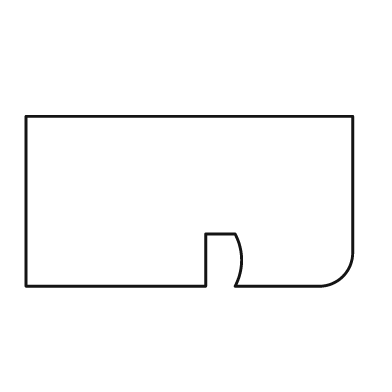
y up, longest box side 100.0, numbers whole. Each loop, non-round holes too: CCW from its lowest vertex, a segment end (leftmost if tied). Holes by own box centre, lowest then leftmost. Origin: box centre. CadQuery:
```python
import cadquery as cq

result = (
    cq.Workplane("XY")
    .moveTo(-50.0, -26.0)
    .lineTo(5.0, -26.0)
    .lineTo(5.0, -10.0)
    .lineTo(14.0, -10.0)
    .threePointArc((16.0, -18.0), (14.0, -26.0))
    .lineTo(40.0, -26.0)
    .threePointArc((47.0, -23.0), (50.0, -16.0))
    .lineTo(50.0, 26.0)
    .lineTo(-50.0, 26.0)
    .close()
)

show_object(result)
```